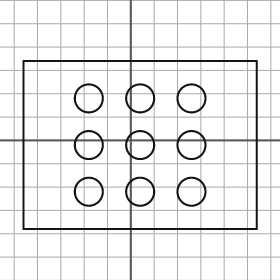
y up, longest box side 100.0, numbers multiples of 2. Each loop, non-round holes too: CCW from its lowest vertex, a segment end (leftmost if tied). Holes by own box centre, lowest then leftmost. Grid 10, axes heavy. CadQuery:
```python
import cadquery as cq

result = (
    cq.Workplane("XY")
    .moveTo(-46.0, -38.0)
    .lineTo(54.0, -38.0)
    .lineTo(54.0, 34.0)
    .lineTo(-46.0, 34.0)
    .close()
    .moveTo(-18.0, -22.0)
    .circle(6.0)
    .moveTo(4.0, -22.0)
    .circle(6.0)
    .moveTo(26.0, -22.0)
    .circle(6.0)
    .moveTo(-18.0, -2.0)
    .circle(6.0)
    .moveTo(4.0, -2.0)
    .circle(6.0)
    .moveTo(26.0, -2.0)
    .circle(6.0)
    .moveTo(-18.0, 18.0)
    .circle(6.0)
    .moveTo(4.0, 18.0)
    .circle(6.0)
    .moveTo(26.0, 18.0)
    .circle(6.0)
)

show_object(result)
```